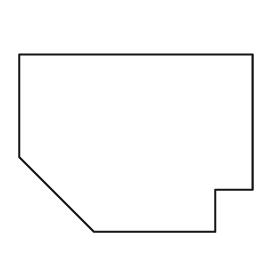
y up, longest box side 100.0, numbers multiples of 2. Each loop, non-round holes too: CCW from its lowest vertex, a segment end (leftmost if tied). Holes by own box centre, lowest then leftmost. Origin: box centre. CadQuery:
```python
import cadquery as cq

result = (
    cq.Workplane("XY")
    .moveTo(-18.0, -38.0)
    .lineTo(34.0, -38.0)
    .lineTo(34.0, -20.0)
    .lineTo(50.0, -20.0)
    .lineTo(50.0, 38.0)
    .lineTo(-50.0, 38.0)
    .lineTo(-50.0, -6.0)
    .close()
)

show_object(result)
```